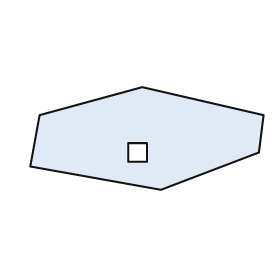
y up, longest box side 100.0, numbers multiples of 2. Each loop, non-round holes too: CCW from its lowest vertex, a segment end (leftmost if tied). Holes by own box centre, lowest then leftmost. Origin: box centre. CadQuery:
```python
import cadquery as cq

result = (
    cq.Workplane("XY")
    .moveTo(6.0, -22.0)
    .lineTo(48.0, -6.0)
    .lineTo(50.0, 10.0)
    .lineTo(-2.0, 22.0)
    .lineTo(-46.0, 10.0)
    .lineTo(-50.0, -12.0)
    .close()
    .moveTo(-8.0, -10.0)
    .lineTo(0.0, -10.0)
    .lineTo(0.0, -2.0)
    .lineTo(-8.0, -2.0)
    .close()
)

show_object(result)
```